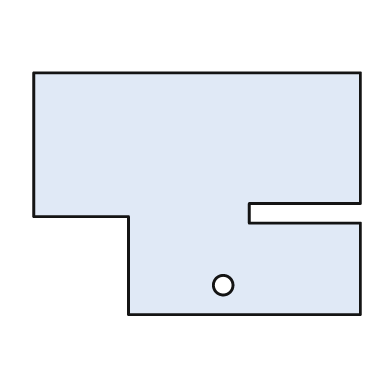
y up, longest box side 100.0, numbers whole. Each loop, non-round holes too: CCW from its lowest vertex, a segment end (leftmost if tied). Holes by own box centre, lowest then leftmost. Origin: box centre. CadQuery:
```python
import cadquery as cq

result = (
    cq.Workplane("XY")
    .moveTo(-21.0, -37.0)
    .lineTo(50.0, -37.0)
    .lineTo(50.0, -9.0)
    .lineTo(16.0, -9.0)
    .lineTo(16.0, -3.0)
    .lineTo(50.0, -3.0)
    .lineTo(50.0, 37.0)
    .lineTo(-50.0, 37.0)
    .lineTo(-50.0, -7.0)
    .lineTo(-21.0, -7.0)
    .close()
    .moveTo(8.0, -28.0)
    .circle(3.0)
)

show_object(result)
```